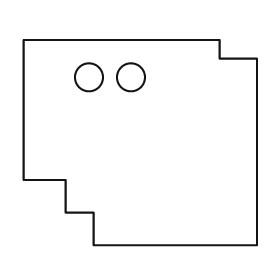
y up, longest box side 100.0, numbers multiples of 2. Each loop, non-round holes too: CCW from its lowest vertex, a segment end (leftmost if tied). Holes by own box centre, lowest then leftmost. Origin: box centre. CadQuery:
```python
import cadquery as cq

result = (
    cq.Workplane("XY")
    .moveTo(-20.0, -44.0)
    .lineTo(50.0, -44.0)
    .lineTo(50.0, 36.0)
    .lineTo(34.0, 36.0)
    .lineTo(34.0, 44.0)
    .lineTo(-50.0, 44.0)
    .lineTo(-50.0, -16.0)
    .lineTo(-32.0, -16.0)
    .lineTo(-32.0, -30.0)
    .lineTo(-20.0, -30.0)
    .close()
    .moveTo(-22.0, 28.0)
    .circle(6.0)
    .moveTo(-4.0, 28.0)
    .circle(6.0)
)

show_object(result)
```